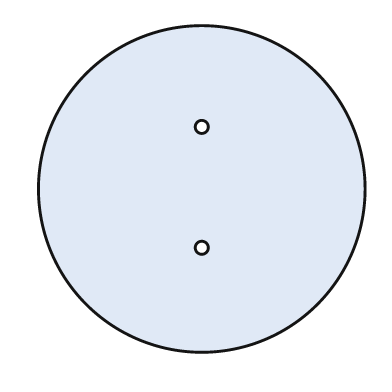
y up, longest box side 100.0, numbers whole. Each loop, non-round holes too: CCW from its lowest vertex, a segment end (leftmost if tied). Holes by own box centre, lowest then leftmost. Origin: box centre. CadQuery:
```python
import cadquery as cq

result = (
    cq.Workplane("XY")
    .moveTo(0.0, 0.0)
    .circle(50.0)
    .moveTo(0.0, -18.0)
    .circle(2.0)
    .moveTo(0.0, 19.0)
    .circle(2.0)
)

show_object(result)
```